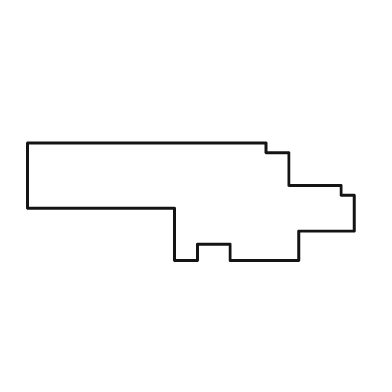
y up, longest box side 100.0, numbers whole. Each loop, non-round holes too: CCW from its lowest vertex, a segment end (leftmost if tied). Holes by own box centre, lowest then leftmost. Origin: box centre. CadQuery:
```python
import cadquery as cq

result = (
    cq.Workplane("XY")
    .moveTo(-5.0, -18.0)
    .lineTo(2.0, -18.0)
    .lineTo(2.0, -13.0)
    .lineTo(12.0, -13.0)
    .lineTo(12.0, -18.0)
    .lineTo(33.0, -18.0)
    .lineTo(33.0, -9.0)
    .lineTo(50.0, -9.0)
    .lineTo(50.0, 2.0)
    .lineTo(46.0, 2.0)
    .lineTo(46.0, 5.0)
    .lineTo(30.0, 5.0)
    .lineTo(30.0, 15.0)
    .lineTo(23.0, 15.0)
    .lineTo(23.0, 18.0)
    .lineTo(-50.0, 18.0)
    .lineTo(-50.0, -2.0)
    .lineTo(-5.0, -2.0)
    .close()
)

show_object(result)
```